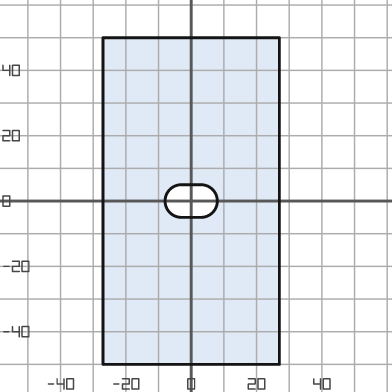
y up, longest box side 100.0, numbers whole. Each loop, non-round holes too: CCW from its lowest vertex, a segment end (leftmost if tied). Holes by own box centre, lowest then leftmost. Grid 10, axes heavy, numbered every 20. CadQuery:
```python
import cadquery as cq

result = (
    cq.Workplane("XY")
    .moveTo(-27.0, -50.0)
    .lineTo(27.0, -50.0)
    .lineTo(27.0, 50.0)
    .lineTo(-27.0, 50.0)
    .close()
    .moveTo(-3.0, -5.0)
    .lineTo(3.0, -5.0)
    .threePointArc((8.0, 0.0), (3.0, 5.0))
    .lineTo(-3.0, 5.0)
    .threePointArc((-8.0, 0.0), (-3.0, -5.0))
    .close()
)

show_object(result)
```